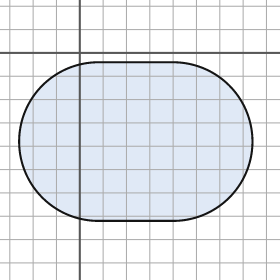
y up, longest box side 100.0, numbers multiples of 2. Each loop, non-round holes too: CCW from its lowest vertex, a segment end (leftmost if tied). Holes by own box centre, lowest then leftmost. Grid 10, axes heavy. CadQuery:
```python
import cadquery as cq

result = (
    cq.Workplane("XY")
    .moveTo(8.0, -72.0)
    .lineTo(40.0, -72.0)
    .threePointArc((74.0, -38.0), (40.0, -4.0))
    .lineTo(8.0, -4.0)
    .threePointArc((-26.0, -38.0), (8.0, -72.0))
    .close()
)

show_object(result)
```